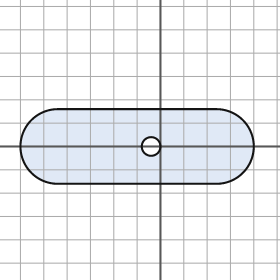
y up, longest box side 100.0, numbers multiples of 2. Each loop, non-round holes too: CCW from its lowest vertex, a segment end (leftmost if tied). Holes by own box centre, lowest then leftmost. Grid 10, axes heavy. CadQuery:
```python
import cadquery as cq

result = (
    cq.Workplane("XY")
    .moveTo(-44.0, -16.0)
    .lineTo(24.0, -16.0)
    .threePointArc((40.0, 0.0), (24.0, 16.0))
    .lineTo(-44.0, 16.0)
    .threePointArc((-60.0, 0.0), (-44.0, -16.0))
    .close()
    .moveTo(-4.0, 0.0)
    .circle(4.0)
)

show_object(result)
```